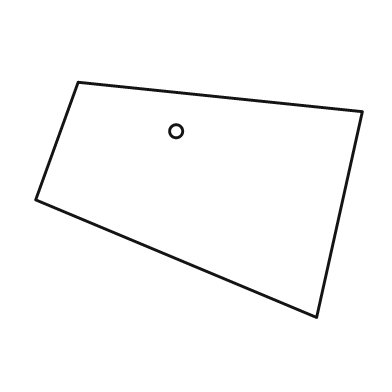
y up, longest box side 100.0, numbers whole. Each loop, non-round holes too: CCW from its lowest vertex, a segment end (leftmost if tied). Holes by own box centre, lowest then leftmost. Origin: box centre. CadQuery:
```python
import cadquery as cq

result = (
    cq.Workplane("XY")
    .moveTo(36.0, -36.0)
    .lineTo(50.0, 27.0)
    .lineTo(-37.0, 36.0)
    .lineTo(-50.0, 0.0)
    .close()
    .moveTo(-7.0, 21.0)
    .circle(2.0)
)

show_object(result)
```